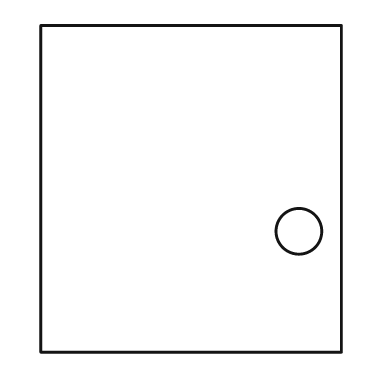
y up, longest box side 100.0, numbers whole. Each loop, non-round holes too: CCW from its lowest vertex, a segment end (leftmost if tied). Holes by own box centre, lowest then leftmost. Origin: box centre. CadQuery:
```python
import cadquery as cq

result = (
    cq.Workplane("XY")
    .moveTo(-46.0, -50.0)
    .lineTo(46.0, -50.0)
    .lineTo(46.0, 50.0)
    .lineTo(-46.0, 50.0)
    .close()
    .moveTo(33.0, -13.0)
    .circle(7.0)
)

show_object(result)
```